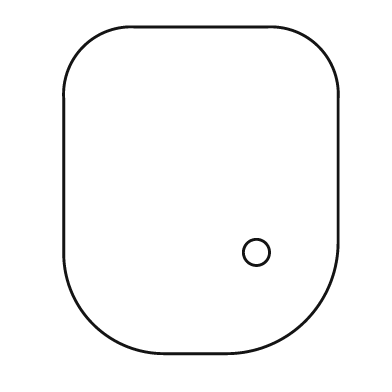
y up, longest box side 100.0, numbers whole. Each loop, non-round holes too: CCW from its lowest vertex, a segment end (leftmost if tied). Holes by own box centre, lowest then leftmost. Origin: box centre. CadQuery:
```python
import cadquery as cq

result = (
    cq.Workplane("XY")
    .moveTo(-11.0, -50.0)
    .lineTo(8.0, -50.0)
    .threePointArc((32.0, -40.0), (42.0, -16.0))
    .lineTo(42.0, 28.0)
    .threePointArc((36.0, 44.0), (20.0, 50.0))
    .lineTo(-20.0, 50.0)
    .threePointArc((-36.0, 44.0), (-42.0, 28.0))
    .lineTo(-42.0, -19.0)
    .threePointArc((-33.0, -41.0), (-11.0, -50.0))
    .close()
    .moveTo(17.0, -19.0)
    .circle(4.0)
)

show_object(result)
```